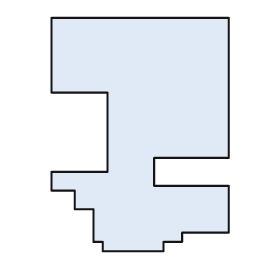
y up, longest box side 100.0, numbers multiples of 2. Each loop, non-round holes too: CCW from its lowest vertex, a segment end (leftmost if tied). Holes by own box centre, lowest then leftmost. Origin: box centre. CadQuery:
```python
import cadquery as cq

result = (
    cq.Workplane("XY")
    .moveTo(-16.0, -50.0)
    .lineTo(10.0, -50.0)
    .lineTo(10.0, -46.0)
    .lineTo(18.0, -46.0)
    .lineTo(18.0, -42.0)
    .lineTo(38.0, -42.0)
    .lineTo(38.0, -22.0)
    .lineTo(6.0, -22.0)
    .lineTo(6.0, -10.0)
    .lineTo(38.0, -10.0)
    .lineTo(38.0, 50.0)
    .lineTo(-38.0, 50.0)
    .lineTo(-38.0, 18.0)
    .lineTo(-14.0, 18.0)
    .lineTo(-14.0, -16.0)
    .lineTo(-38.0, -16.0)
    .lineTo(-38.0, -24.0)
    .lineTo(-28.0, -24.0)
    .lineTo(-28.0, -32.0)
    .lineTo(-20.0, -32.0)
    .lineTo(-20.0, -46.0)
    .lineTo(-16.0, -46.0)
    .close()
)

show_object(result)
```